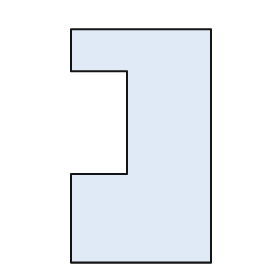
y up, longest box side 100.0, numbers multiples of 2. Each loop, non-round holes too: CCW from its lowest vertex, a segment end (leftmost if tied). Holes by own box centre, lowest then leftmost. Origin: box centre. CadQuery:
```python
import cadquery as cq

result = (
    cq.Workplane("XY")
    .moveTo(-30.0, -50.0)
    .lineTo(30.0, -50.0)
    .lineTo(30.0, 50.0)
    .lineTo(-30.0, 50.0)
    .lineTo(-30.0, 32.0)
    .lineTo(-6.0, 32.0)
    .lineTo(-6.0, -12.0)
    .lineTo(-30.0, -12.0)
    .close()
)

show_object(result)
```